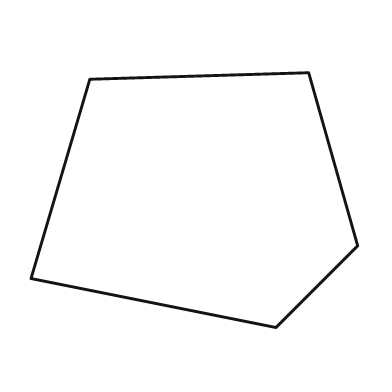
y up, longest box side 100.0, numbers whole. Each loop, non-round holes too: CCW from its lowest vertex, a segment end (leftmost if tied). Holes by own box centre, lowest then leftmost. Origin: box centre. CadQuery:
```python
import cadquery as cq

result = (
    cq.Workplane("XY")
    .moveTo(25.0, -39.0)
    .lineTo(50.0, -14.0)
    .lineTo(35.0, 39.0)
    .lineTo(-32.0, 37.0)
    .lineTo(-50.0, -24.0)
    .close()
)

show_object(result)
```